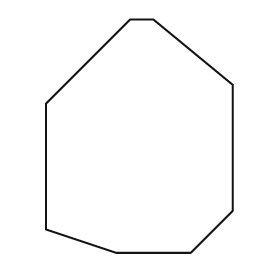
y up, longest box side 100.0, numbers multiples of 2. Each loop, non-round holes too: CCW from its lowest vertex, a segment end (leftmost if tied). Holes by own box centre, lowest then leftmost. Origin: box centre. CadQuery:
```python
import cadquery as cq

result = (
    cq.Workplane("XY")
    .moveTo(-10.0, -50.0)
    .lineTo(22.0, -50.0)
    .lineTo(40.0, -32.0)
    .lineTo(40.0, 22.0)
    .lineTo(6.0, 50.0)
    .lineTo(-4.0, 50.0)
    .lineTo(-40.0, 14.0)
    .lineTo(-40.0, -40.0)
    .close()
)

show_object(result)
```